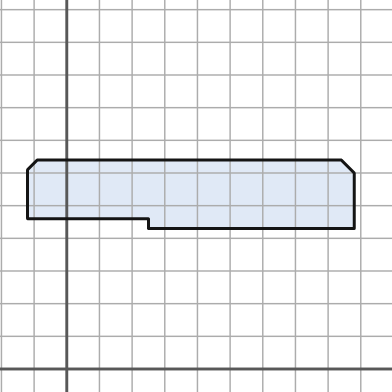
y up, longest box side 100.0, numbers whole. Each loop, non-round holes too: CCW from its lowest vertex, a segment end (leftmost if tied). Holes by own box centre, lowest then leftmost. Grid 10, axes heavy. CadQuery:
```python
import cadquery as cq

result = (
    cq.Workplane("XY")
    .moveTo(25.0, 43.0)
    .lineTo(88.0, 43.0)
    .lineTo(88.0, 60.0)
    .lineTo(84.0, 64.0)
    .lineTo(-9.0, 64.0)
    .lineTo(-12.0, 61.0)
    .lineTo(-12.0, 46.0)
    .lineTo(25.0, 46.0)
    .close()
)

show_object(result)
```